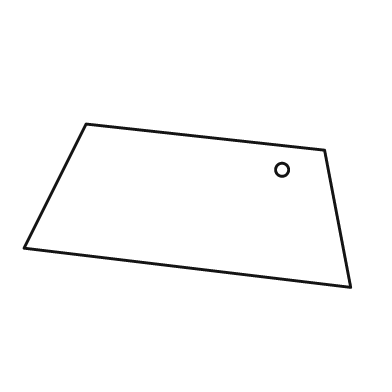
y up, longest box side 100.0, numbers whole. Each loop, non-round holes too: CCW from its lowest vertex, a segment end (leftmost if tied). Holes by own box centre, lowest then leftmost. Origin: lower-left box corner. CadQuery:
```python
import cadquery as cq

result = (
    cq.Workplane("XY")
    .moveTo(100.0, 0.0)
    .lineTo(92.0, 42.0)
    .lineTo(19.0, 50.0)
    .lineTo(0.0, 12.0)
    .close()
    .moveTo(79.0, 36.0)
    .circle(2.0)
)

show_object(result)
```